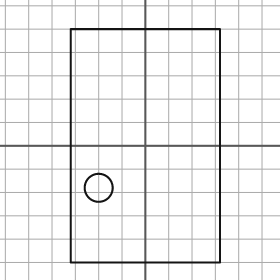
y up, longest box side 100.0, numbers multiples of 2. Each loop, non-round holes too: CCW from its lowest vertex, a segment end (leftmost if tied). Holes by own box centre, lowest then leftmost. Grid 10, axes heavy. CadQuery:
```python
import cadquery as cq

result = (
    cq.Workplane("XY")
    .moveTo(-32.0, -50.0)
    .lineTo(32.0, -50.0)
    .lineTo(32.0, 50.0)
    .lineTo(-32.0, 50.0)
    .close()
    .moveTo(-20.0, -18.0)
    .circle(6.0)
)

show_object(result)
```